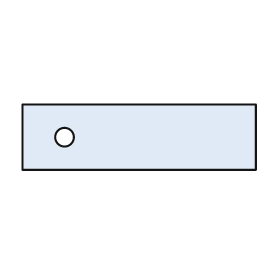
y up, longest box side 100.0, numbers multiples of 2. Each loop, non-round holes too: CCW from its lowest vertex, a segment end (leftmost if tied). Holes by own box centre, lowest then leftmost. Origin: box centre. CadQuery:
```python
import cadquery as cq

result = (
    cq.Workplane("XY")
    .moveTo(-50.0, -14.0)
    .lineTo(50.0, -14.0)
    .lineTo(50.0, 14.0)
    .lineTo(-50.0, 14.0)
    .close()
    .moveTo(-32.0, 0.0)
    .circle(4.0)
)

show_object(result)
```